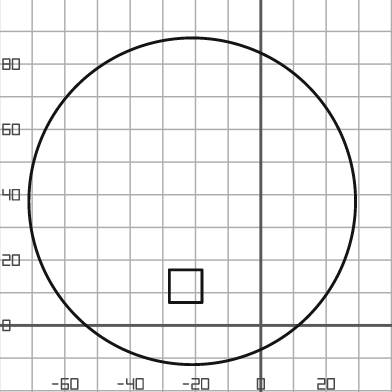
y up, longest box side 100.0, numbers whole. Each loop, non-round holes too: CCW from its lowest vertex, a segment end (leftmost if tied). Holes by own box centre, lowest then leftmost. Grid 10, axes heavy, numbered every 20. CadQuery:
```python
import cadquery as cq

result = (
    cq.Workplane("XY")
    .moveTo(-21.0, 38.0)
    .circle(50.0)
    .moveTo(-28.0, 7.0)
    .lineTo(-18.0, 7.0)
    .lineTo(-18.0, 17.0)
    .lineTo(-28.0, 17.0)
    .close()
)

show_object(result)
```